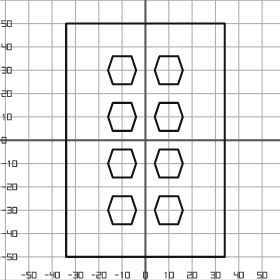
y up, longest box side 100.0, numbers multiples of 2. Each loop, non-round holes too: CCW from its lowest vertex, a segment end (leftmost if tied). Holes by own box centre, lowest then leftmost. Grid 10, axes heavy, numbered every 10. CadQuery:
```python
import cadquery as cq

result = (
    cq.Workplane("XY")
    .moveTo(-34.0, -50.0)
    .lineTo(34.0, -50.0)
    .lineTo(34.0, 50.0)
    .lineTo(-34.0, 50.0)
    .close()
    .moveTo(-14.0, -36.0)
    .lineTo(-6.0, -36.0)
    .lineTo(-4.0, -30.0)
    .lineTo(-6.0, -24.0)
    .lineTo(-14.0, -24.0)
    .lineTo(-16.0, -30.0)
    .close()
    .moveTo(6.0, -36.0)
    .lineTo(14.0, -36.0)
    .lineTo(16.0, -30.0)
    .lineTo(14.0, -24.0)
    .lineTo(6.0, -24.0)
    .lineTo(4.0, -30.0)
    .close()
    .moveTo(-14.0, -16.0)
    .lineTo(-6.0, -16.0)
    .lineTo(-4.0, -10.0)
    .lineTo(-6.0, -4.0)
    .lineTo(-14.0, -4.0)
    .lineTo(-16.0, -10.0)
    .close()
    .moveTo(6.0, -16.0)
    .lineTo(14.0, -16.0)
    .lineTo(16.0, -10.0)
    .lineTo(14.0, -4.0)
    .lineTo(6.0, -4.0)
    .lineTo(4.0, -10.0)
    .close()
    .moveTo(-14.0, 4.0)
    .lineTo(-6.0, 4.0)
    .lineTo(-4.0, 10.0)
    .lineTo(-6.0, 16.0)
    .lineTo(-14.0, 16.0)
    .lineTo(-16.0, 10.0)
    .close()
    .moveTo(6.0, 4.0)
    .lineTo(14.0, 4.0)
    .lineTo(16.0, 10.0)
    .lineTo(14.0, 16.0)
    .lineTo(6.0, 16.0)
    .lineTo(4.0, 10.0)
    .close()
    .moveTo(-14.0, 24.0)
    .lineTo(-6.0, 24.0)
    .lineTo(-4.0, 30.0)
    .lineTo(-6.0, 36.0)
    .lineTo(-14.0, 36.0)
    .lineTo(-16.0, 30.0)
    .close()
    .moveTo(6.0, 24.0)
    .lineTo(14.0, 24.0)
    .lineTo(16.0, 30.0)
    .lineTo(14.0, 36.0)
    .lineTo(6.0, 36.0)
    .lineTo(4.0, 30.0)
    .close()
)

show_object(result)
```